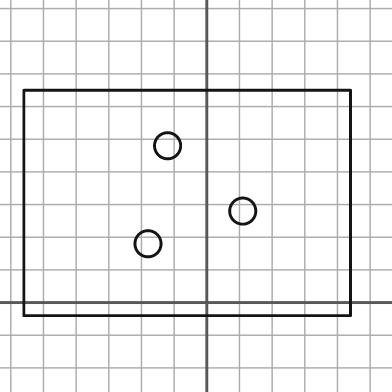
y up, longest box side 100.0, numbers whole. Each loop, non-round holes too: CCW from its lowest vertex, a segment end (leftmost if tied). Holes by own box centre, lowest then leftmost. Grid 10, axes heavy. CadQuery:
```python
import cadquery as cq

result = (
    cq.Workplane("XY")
    .moveTo(-56.0, -4.0)
    .lineTo(44.0, -4.0)
    .lineTo(44.0, 65.0)
    .lineTo(-56.0, 65.0)
    .close()
    .moveTo(-18.0, 18.0)
    .circle(4.0)
    .moveTo(11.0, 28.0)
    .circle(4.0)
    .moveTo(-12.0, 48.0)
    .circle(4.0)
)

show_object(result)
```